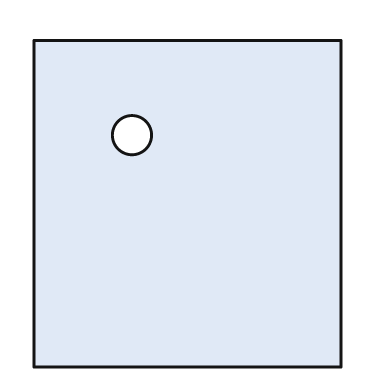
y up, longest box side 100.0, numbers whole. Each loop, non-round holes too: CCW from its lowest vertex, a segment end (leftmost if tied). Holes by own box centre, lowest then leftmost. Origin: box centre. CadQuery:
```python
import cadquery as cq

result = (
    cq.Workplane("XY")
    .moveTo(-47.0, -50.0)
    .lineTo(47.0, -50.0)
    .lineTo(47.0, 50.0)
    .lineTo(-47.0, 50.0)
    .close()
    .moveTo(-17.0, 21.0)
    .circle(6.0)
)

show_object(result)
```